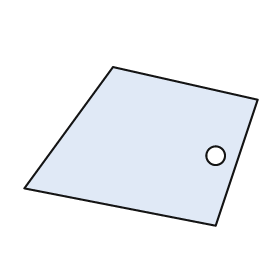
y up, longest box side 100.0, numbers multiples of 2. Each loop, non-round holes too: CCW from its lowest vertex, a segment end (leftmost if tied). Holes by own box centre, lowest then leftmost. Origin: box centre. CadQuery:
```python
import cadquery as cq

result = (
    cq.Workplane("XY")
    .moveTo(32.0, -34.0)
    .lineTo(50.0, 20.0)
    .lineTo(-12.0, 34.0)
    .lineTo(-50.0, -18.0)
    .close()
    .moveTo(32.0, -4.0)
    .circle(4.0)
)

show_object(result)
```